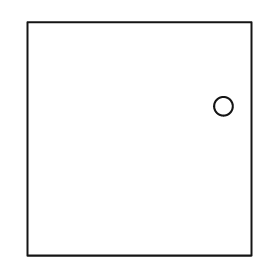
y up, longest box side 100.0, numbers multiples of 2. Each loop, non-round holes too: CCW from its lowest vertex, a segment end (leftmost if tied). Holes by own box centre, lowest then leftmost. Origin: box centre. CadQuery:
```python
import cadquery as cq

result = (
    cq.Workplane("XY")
    .moveTo(-48.0, -50.0)
    .lineTo(48.0, -50.0)
    .lineTo(48.0, 50.0)
    .lineTo(-48.0, 50.0)
    .close()
    .moveTo(36.0, 14.0)
    .circle(4.0)
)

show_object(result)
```